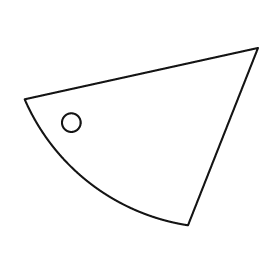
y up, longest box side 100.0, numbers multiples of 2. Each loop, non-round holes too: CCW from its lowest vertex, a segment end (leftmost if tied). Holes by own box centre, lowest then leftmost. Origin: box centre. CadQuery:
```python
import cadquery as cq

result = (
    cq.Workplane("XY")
    .moveTo(20.0, -38.0)
    .lineTo(50.0, 38.0)
    .lineTo(-50.0, 16.0)
    .threePointArc((-22.0, -20.0), (20.0, -38.0))
    .close()
    .moveTo(-30.0, 6.0)
    .circle(4.0)
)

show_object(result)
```